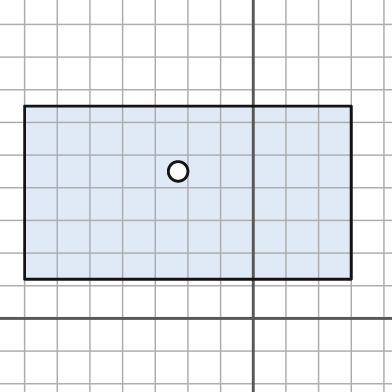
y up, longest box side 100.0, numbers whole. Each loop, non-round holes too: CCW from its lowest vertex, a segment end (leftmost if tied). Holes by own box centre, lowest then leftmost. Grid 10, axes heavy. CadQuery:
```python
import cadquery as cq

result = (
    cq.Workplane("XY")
    .moveTo(-70.0, 12.0)
    .lineTo(30.0, 12.0)
    .lineTo(30.0, 65.0)
    .lineTo(-70.0, 65.0)
    .close()
    .moveTo(-23.0, 45.0)
    .circle(3.0)
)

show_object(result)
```